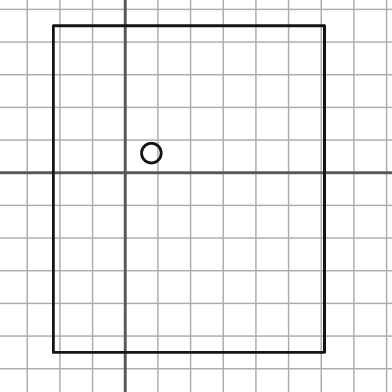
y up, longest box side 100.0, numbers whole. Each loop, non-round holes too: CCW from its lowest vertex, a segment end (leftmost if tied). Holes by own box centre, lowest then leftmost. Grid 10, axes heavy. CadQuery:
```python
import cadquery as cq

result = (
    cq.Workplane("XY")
    .moveTo(-22.0, -55.0)
    .lineTo(61.0, -55.0)
    .lineTo(61.0, 45.0)
    .lineTo(-22.0, 45.0)
    .close()
    .moveTo(8.0, 6.0)
    .circle(3.0)
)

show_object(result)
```